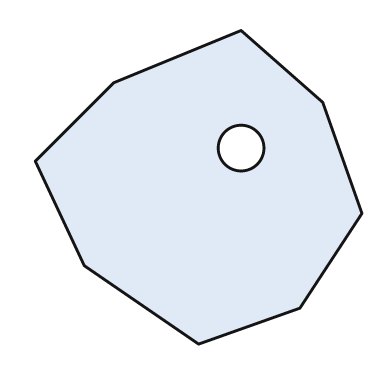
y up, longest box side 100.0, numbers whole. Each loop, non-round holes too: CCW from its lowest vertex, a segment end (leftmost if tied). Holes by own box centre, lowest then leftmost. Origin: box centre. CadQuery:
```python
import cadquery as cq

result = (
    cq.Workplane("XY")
    .moveTo(0.0, -48.0)
    .lineTo(31.0, -37.0)
    .lineTo(50.0, -8.0)
    .lineTo(38.0, 26.0)
    .lineTo(13.0, 48.0)
    .lineTo(-26.0, 32.0)
    .lineTo(-50.0, 8.0)
    .lineTo(-35.0, -24.0)
    .close()
    .moveTo(13.0, 12.0)
    .circle(7.0)
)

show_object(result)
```